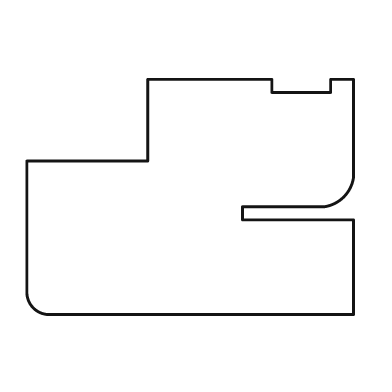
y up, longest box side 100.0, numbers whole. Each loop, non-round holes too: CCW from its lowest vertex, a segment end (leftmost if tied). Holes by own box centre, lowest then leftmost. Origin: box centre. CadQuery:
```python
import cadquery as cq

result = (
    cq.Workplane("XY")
    .moveTo(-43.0, -36.0)
    .lineTo(50.0, -36.0)
    .lineTo(50.0, -7.0)
    .lineTo(16.0, -7.0)
    .lineTo(16.0, -3.0)
    .lineTo(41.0, -3.0)
    .threePointArc((47.0, 0.0), (50.0, 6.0))
    .lineTo(50.0, 36.0)
    .lineTo(43.0, 36.0)
    .lineTo(43.0, 32.0)
    .lineTo(25.0, 32.0)
    .lineTo(25.0, 36.0)
    .lineTo(-13.0, 36.0)
    .lineTo(-13.0, 11.0)
    .lineTo(-50.0, 11.0)
    .lineTo(-50.0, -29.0)
    .threePointArc((-48.0, -34.0), (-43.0, -36.0))
    .close()
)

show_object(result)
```